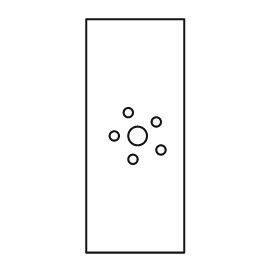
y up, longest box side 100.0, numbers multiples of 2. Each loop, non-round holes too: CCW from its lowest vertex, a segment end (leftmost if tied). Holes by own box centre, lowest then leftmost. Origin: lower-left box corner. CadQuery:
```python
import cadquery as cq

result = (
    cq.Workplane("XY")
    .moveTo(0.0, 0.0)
    .lineTo(42.0, 0.0)
    .lineTo(42.0, 100.0)
    .lineTo(0.0, 100.0)
    .close()
    .moveTo(20.0, 40.0)
    .circle(2.0)
    .moveTo(32.0, 44.0)
    .circle(2.0)
    .moveTo(12.0, 50.0)
    .circle(2.0)
    .moveTo(22.0, 50.0)
    .circle(4.0)
    .moveTo(30.0, 56.0)
    .circle(2.0)
    .moveTo(18.0, 60.0)
    .circle(2.0)
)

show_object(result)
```